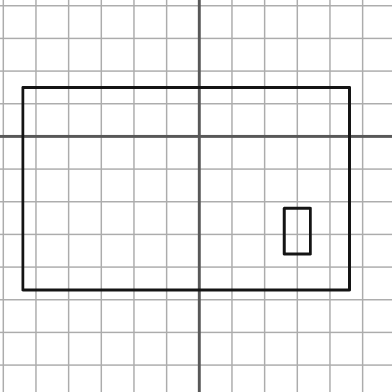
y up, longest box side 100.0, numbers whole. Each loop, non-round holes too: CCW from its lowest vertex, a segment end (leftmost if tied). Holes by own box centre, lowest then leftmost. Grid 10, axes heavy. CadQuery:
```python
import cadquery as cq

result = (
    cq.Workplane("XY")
    .moveTo(-54.0, -47.0)
    .lineTo(46.0, -47.0)
    .lineTo(46.0, 15.0)
    .lineTo(-54.0, 15.0)
    .close()
    .moveTo(26.0, -36.0)
    .lineTo(34.0, -36.0)
    .lineTo(34.0, -22.0)
    .lineTo(26.0, -22.0)
    .close()
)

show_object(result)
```